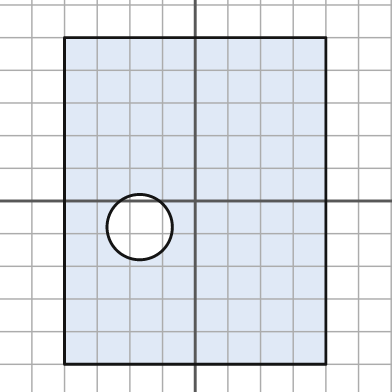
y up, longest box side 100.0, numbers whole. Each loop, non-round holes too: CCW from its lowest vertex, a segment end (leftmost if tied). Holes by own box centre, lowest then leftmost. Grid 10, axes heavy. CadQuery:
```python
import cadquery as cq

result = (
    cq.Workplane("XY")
    .moveTo(-40.0, -50.0)
    .lineTo(40.0, -50.0)
    .lineTo(40.0, 50.0)
    .lineTo(-40.0, 50.0)
    .close()
    .moveTo(-17.0, -8.0)
    .circle(10.0)
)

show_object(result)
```